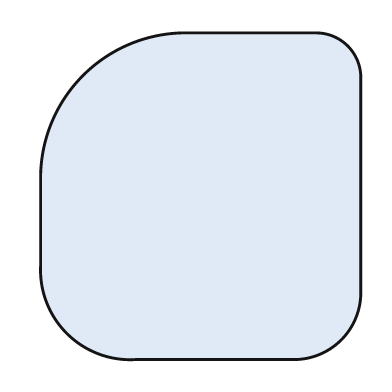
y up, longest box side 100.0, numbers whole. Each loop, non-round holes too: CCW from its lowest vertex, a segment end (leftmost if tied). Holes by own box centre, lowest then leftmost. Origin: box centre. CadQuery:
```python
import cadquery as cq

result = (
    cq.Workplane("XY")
    .moveTo(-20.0, -50.0)
    .lineTo(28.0, -50.0)
    .threePointArc((43.0, -44.0), (49.0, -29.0))
    .lineTo(49.0, 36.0)
    .threePointArc((45.0, 46.0), (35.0, 50.0))
    .lineTo(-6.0, 50.0)
    .threePointArc((-36.0, 37.0), (-49.0, 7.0))
    .lineTo(-49.0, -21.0)
    .threePointArc((-41.0, -42.0), (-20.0, -50.0))
    .close()
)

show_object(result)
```